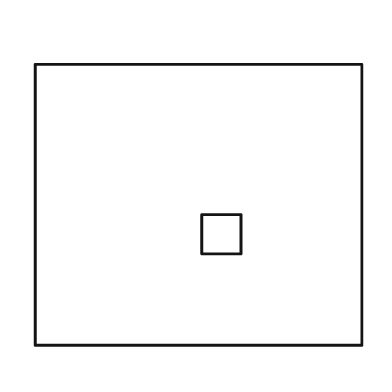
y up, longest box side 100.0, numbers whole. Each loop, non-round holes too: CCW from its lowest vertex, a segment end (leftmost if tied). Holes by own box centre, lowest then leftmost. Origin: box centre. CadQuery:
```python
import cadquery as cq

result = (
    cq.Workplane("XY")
    .moveTo(-50.0, -43.0)
    .lineTo(50.0, -43.0)
    .lineTo(50.0, 43.0)
    .lineTo(-50.0, 43.0)
    .close()
    .moveTo(1.0, -15.0)
    .lineTo(13.0, -15.0)
    .lineTo(13.0, -3.0)
    .lineTo(1.0, -3.0)
    .close()
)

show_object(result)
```